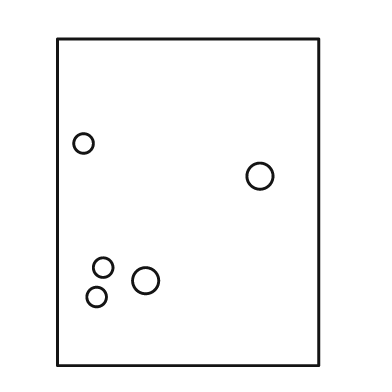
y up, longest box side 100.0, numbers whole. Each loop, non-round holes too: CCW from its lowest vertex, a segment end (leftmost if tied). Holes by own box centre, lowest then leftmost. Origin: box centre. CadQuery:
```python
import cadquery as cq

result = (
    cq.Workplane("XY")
    .moveTo(-40.0, -50.0)
    .lineTo(40.0, -50.0)
    .lineTo(40.0, 50.0)
    .lineTo(-40.0, 50.0)
    .close()
    .moveTo(-28.0, -29.0)
    .circle(3.0)
    .moveTo(-13.0, -24.0)
    .circle(4.0)
    .moveTo(-26.0, -20.0)
    .circle(3.0)
    .moveTo(22.0, 8.0)
    .circle(4.0)
    .moveTo(-32.0, 18.0)
    .circle(3.0)
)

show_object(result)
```